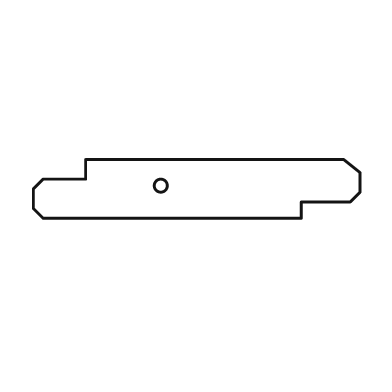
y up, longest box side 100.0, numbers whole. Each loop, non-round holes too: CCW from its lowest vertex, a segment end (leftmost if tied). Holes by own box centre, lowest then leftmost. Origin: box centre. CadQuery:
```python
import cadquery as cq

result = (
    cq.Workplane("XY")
    .moveTo(-47.0, -9.0)
    .lineTo(32.0, -9.0)
    .lineTo(32.0, -4.0)
    .lineTo(47.0, -4.0)
    .lineTo(50.0, -1.0)
    .lineTo(50.0, 5.0)
    .lineTo(45.0, 9.0)
    .lineTo(-34.0, 9.0)
    .lineTo(-34.0, 3.0)
    .lineTo(-47.0, 3.0)
    .lineTo(-50.0, 0.0)
    .lineTo(-50.0, -6.0)
    .close()
    .moveTo(-11.0, 1.0)
    .circle(2.0)
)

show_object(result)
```